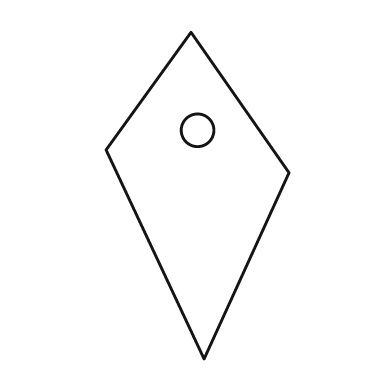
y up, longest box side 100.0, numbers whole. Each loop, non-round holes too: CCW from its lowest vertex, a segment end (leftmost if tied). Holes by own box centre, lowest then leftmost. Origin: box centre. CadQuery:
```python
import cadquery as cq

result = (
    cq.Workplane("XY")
    .moveTo(2.0, -50.0)
    .lineTo(28.0, 7.0)
    .lineTo(-2.0, 50.0)
    .lineTo(-28.0, 14.0)
    .close()
    .moveTo(0.0, 20.0)
    .circle(5.0)
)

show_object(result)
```